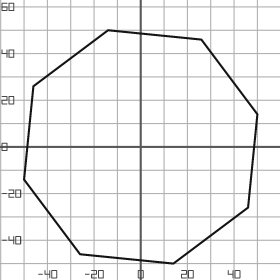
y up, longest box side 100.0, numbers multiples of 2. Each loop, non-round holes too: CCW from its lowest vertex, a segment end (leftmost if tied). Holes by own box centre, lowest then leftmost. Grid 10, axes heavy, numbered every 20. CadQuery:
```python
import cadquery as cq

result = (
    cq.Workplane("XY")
    .moveTo(14.0, -50.0)
    .lineTo(46.0, -26.0)
    .lineTo(50.0, 14.0)
    .lineTo(26.0, 46.0)
    .lineTo(-14.0, 50.0)
    .lineTo(-46.0, 26.0)
    .lineTo(-50.0, -14.0)
    .lineTo(-26.0, -46.0)
    .close()
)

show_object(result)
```